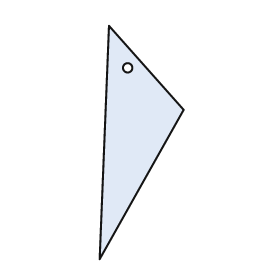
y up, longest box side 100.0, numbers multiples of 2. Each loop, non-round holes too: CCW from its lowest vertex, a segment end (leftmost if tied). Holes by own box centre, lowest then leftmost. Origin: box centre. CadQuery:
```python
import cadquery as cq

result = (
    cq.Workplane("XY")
    .moveTo(-18.0, -50.0)
    .lineTo(18.0, 14.0)
    .lineTo(-14.0, 50.0)
    .close()
    .moveTo(-6.0, 32.0)
    .circle(2.0)
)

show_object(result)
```